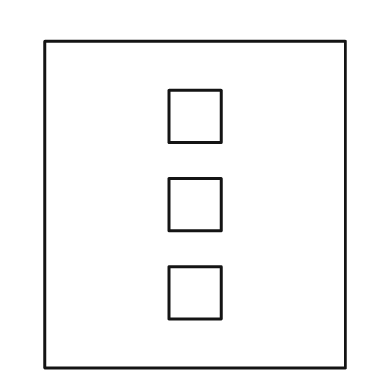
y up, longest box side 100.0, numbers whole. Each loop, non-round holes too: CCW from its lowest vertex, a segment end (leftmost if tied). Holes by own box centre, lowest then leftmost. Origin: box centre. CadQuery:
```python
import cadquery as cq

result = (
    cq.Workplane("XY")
    .moveTo(-46.0, -50.0)
    .lineTo(46.0, -50.0)
    .lineTo(46.0, 50.0)
    .lineTo(-46.0, 50.0)
    .close()
    .moveTo(-8.0, -35.0)
    .lineTo(8.0, -35.0)
    .lineTo(8.0, -19.0)
    .lineTo(-8.0, -19.0)
    .close()
    .moveTo(-8.0, -8.0)
    .lineTo(8.0, -8.0)
    .lineTo(8.0, 8.0)
    .lineTo(-8.0, 8.0)
    .close()
    .moveTo(-8.0, 19.0)
    .lineTo(8.0, 19.0)
    .lineTo(8.0, 35.0)
    .lineTo(-8.0, 35.0)
    .close()
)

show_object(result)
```